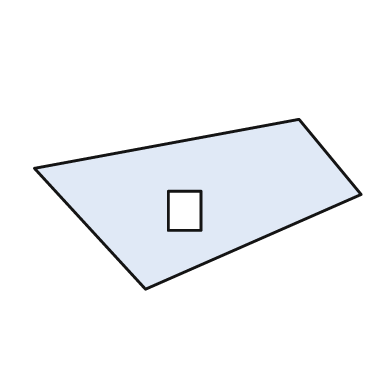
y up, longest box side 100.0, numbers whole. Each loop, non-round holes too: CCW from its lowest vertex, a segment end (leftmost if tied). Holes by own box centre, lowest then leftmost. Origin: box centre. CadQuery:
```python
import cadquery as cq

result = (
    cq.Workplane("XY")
    .moveTo(-16.0, -26.0)
    .lineTo(50.0, 3.0)
    .lineTo(31.0, 26.0)
    .lineTo(-50.0, 11.0)
    .close()
    .moveTo(-9.0, -8.0)
    .lineTo(1.0, -8.0)
    .lineTo(1.0, 4.0)
    .lineTo(-9.0, 4.0)
    .close()
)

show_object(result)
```